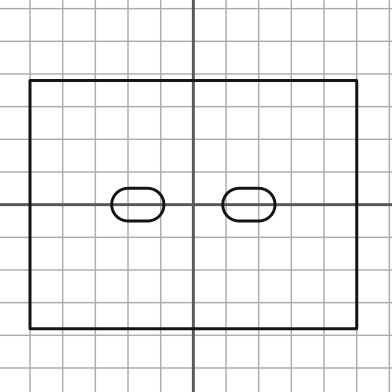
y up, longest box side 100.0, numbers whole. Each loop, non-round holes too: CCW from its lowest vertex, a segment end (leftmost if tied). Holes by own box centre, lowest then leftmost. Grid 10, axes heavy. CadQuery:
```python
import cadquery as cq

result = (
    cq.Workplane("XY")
    .moveTo(-50.0, -38.0)
    .lineTo(50.0, -38.0)
    .lineTo(50.0, 38.0)
    .lineTo(-50.0, 38.0)
    .close()
    .moveTo(-20.0, -5.0)
    .lineTo(-14.0, -5.0)
    .threePointArc((-9.0, 0.0), (-14.0, 5.0))
    .lineTo(-20.0, 5.0)
    .threePointArc((-25.0, 0.0), (-20.0, -5.0))
    .close()
    .moveTo(14.0, -5.0)
    .lineTo(20.0, -5.0)
    .threePointArc((25.0, 0.0), (20.0, 5.0))
    .lineTo(14.0, 5.0)
    .threePointArc((9.0, 0.0), (14.0, -5.0))
    .close()
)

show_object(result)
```